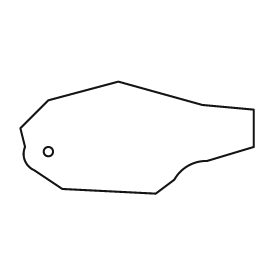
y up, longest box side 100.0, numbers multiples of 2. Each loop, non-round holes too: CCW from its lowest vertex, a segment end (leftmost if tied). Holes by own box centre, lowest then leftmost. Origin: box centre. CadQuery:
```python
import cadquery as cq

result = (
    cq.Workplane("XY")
    .moveTo(8.0, -24.0)
    .lineTo(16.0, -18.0)
    .threePointArc((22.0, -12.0), (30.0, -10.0))
    .lineTo(50.0, -4.0)
    .lineTo(50.0, 12.0)
    .lineTo(28.0, 14.0)
    .lineTo(-8.0, 24.0)
    .lineTo(-38.0, 16.0)
    .lineTo(-50.0, 4.0)
    .lineTo(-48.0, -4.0)
    .threePointArc((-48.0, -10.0), (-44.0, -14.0))
    .lineTo(-32.0, -22.0)
    .close()
    .moveTo(-38.0, -6.0)
    .circle(2.0)
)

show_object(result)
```